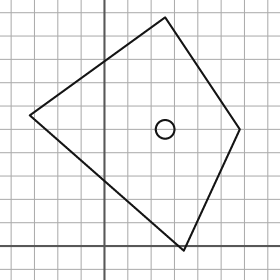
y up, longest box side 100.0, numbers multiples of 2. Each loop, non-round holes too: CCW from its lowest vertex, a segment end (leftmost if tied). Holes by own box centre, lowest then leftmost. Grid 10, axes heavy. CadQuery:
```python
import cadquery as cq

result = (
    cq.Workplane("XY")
    .moveTo(34.0, -2.0)
    .lineTo(58.0, 50.0)
    .lineTo(26.0, 98.0)
    .lineTo(-32.0, 56.0)
    .close()
    .moveTo(26.0, 50.0)
    .circle(4.0)
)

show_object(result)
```